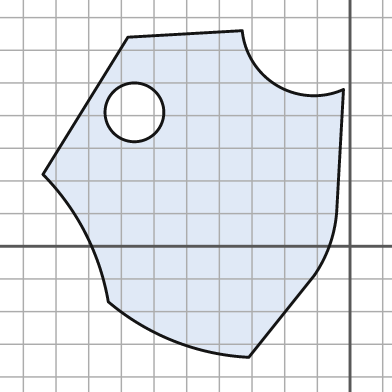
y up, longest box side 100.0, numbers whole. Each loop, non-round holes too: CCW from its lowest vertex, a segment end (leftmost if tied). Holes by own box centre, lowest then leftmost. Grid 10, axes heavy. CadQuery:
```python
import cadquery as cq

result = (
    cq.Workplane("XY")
    .moveTo(-31.0, -34.0)
    .lineTo(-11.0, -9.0)
    .threePointArc((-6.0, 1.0), (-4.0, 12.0))
    .lineTo(-2.0, 48.0)
    .threePointArc((-22.0, 49.0), (-33.0, 66.0))
    .lineTo(-68.0, 64.0)
    .lineTo(-94.0, 22.0)
    .threePointArc((-81.0, 4.0), (-74.0, -17.0))
    .threePointArc((-54.0, -29.0), (-31.0, -34.0))
    .close()
    .moveTo(-66.0, 41.0)
    .circle(9.0)
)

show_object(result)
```